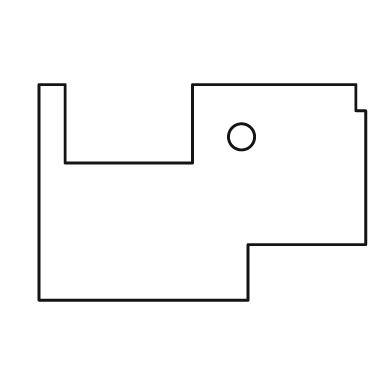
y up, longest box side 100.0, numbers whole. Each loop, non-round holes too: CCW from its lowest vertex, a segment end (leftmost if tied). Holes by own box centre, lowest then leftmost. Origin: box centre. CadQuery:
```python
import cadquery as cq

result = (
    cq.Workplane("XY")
    .moveTo(-50.0, -33.0)
    .lineTo(14.0, -33.0)
    .lineTo(14.0, -16.0)
    .lineTo(50.0, -16.0)
    .lineTo(50.0, 25.0)
    .lineTo(47.0, 25.0)
    .lineTo(47.0, 33.0)
    .lineTo(-3.0, 33.0)
    .lineTo(-3.0, 9.0)
    .lineTo(-42.0, 9.0)
    .lineTo(-42.0, 33.0)
    .lineTo(-50.0, 33.0)
    .close()
    .moveTo(12.0, 17.0)
    .circle(4.0)
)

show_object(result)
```